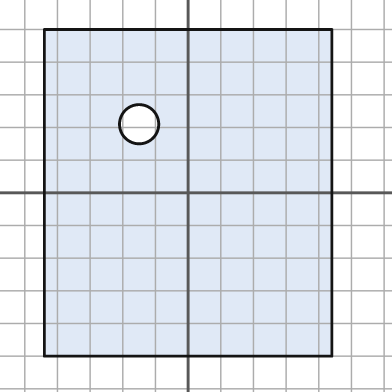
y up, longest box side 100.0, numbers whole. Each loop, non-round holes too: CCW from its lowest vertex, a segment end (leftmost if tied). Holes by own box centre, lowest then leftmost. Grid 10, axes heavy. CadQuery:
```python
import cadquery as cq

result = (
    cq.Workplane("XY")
    .moveTo(-44.0, -50.0)
    .lineTo(44.0, -50.0)
    .lineTo(44.0, 50.0)
    .lineTo(-44.0, 50.0)
    .close()
    .moveTo(-15.0, 21.0)
    .circle(6.0)
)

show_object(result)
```